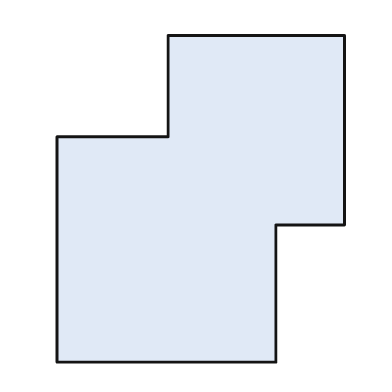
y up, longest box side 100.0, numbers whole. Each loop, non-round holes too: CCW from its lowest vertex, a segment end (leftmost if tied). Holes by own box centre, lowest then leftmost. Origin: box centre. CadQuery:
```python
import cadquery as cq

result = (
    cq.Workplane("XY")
    .moveTo(-44.0, -50.0)
    .lineTo(23.0, -50.0)
    .lineTo(23.0, -8.0)
    .lineTo(44.0, -8.0)
    .lineTo(44.0, 50.0)
    .lineTo(-10.0, 50.0)
    .lineTo(-10.0, 19.0)
    .lineTo(-44.0, 19.0)
    .close()
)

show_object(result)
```